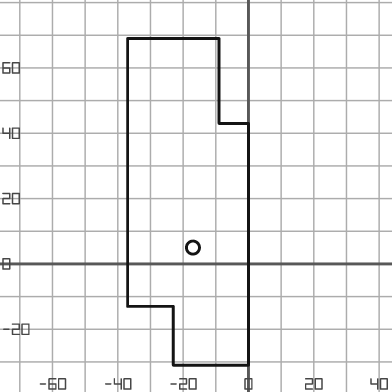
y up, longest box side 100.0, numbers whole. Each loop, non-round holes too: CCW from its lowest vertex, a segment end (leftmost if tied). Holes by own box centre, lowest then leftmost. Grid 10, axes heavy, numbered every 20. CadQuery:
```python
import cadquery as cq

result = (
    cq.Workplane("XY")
    .moveTo(-23.0, -31.0)
    .lineTo(0.0, -31.0)
    .lineTo(0.0, 43.0)
    .lineTo(-9.0, 43.0)
    .lineTo(-9.0, 69.0)
    .lineTo(-37.0, 69.0)
    .lineTo(-37.0, -13.0)
    .lineTo(-23.0, -13.0)
    .close()
    .moveTo(-17.0, 5.0)
    .circle(2.0)
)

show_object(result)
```